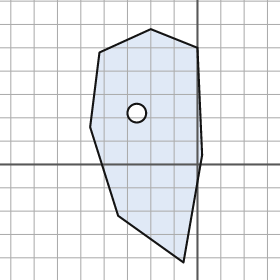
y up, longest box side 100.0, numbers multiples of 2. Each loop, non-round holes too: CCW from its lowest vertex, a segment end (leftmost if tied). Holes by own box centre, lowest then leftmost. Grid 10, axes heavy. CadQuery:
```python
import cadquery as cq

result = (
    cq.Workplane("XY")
    .moveTo(-6.0, -42.0)
    .lineTo(2.0, 4.0)
    .lineTo(0.0, 50.0)
    .lineTo(-20.0, 58.0)
    .lineTo(-42.0, 48.0)
    .lineTo(-46.0, 16.0)
    .lineTo(-34.0, -22.0)
    .close()
    .moveTo(-26.0, 22.0)
    .circle(4.0)
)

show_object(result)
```